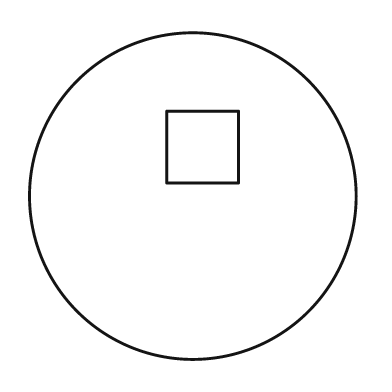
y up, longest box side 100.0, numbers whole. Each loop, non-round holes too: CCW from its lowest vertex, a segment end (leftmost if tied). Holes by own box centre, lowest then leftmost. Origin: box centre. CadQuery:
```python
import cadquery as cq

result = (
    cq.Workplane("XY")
    .moveTo(0.0, 0.0)
    .circle(50.0)
    .moveTo(-8.0, 4.0)
    .lineTo(14.0, 4.0)
    .lineTo(14.0, 26.0)
    .lineTo(-8.0, 26.0)
    .close()
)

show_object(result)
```